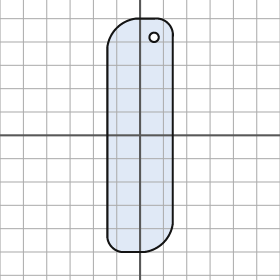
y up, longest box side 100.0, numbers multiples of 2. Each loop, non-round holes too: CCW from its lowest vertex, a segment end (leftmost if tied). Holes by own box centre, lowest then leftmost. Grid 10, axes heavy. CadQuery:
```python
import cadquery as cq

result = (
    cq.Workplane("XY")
    .moveTo(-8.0, -50.0)
    .lineTo(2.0, -50.0)
    .threePointArc((10.0, -46.0), (14.0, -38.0))
    .lineTo(14.0, 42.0)
    .threePointArc((12.0, 48.0), (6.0, 50.0))
    .lineTo(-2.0, 50.0)
    .threePointArc((-10.0, 46.0), (-14.0, 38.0))
    .lineTo(-14.0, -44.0)
    .threePointArc((-12.0, -48.0), (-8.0, -50.0))
    .close()
    .moveTo(6.0, 42.0)
    .circle(2.0)
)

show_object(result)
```